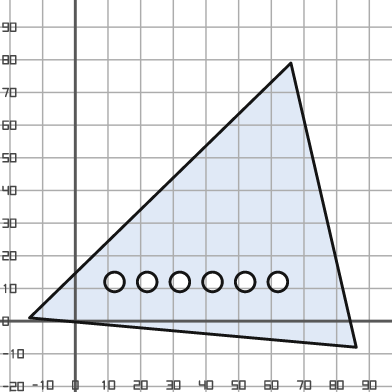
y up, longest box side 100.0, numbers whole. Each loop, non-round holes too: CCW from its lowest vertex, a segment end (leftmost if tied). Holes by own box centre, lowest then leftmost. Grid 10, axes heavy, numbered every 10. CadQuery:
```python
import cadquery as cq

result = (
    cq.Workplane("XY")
    .moveTo(86.0, -8.0)
    .lineTo(66.0, 79.0)
    .lineTo(-14.0, 1.0)
    .close()
    .moveTo(12.0, 12.0)
    .circle(3.0)
    .moveTo(22.0, 12.0)
    .circle(3.0)
    .moveTo(32.0, 12.0)
    .circle(3.0)
    .moveTo(42.0, 12.0)
    .circle(3.0)
    .moveTo(52.0, 12.0)
    .circle(3.0)
    .moveTo(62.0, 12.0)
    .circle(3.0)
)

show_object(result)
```